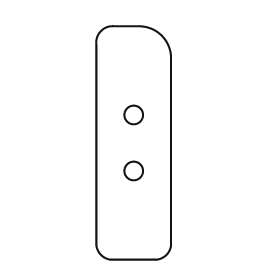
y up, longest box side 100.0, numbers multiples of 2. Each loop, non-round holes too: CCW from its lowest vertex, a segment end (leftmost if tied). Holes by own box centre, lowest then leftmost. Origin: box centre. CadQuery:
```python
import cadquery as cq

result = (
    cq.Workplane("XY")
    .moveTo(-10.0, -50.0)
    .lineTo(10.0, -50.0)
    .threePointArc((14.0, -48.0), (16.0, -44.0))
    .lineTo(16.0, 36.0)
    .threePointArc((12.0, 46.0), (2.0, 50.0))
    .lineTo(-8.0, 50.0)
    .threePointArc((-14.0, 48.0), (-16.0, 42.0))
    .lineTo(-16.0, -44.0)
    .threePointArc((-14.0, -48.0), (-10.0, -50.0))
    .close()
    .moveTo(0.0, -12.0)
    .circle(4.0)
    .moveTo(0.0, 12.0)
    .circle(4.0)
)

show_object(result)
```